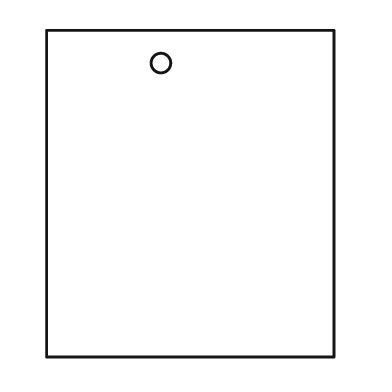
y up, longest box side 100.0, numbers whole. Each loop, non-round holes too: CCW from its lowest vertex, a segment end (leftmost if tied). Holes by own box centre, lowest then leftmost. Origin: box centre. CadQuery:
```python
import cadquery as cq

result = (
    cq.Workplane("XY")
    .moveTo(-44.0, -50.0)
    .lineTo(44.0, -50.0)
    .lineTo(44.0, 50.0)
    .lineTo(-44.0, 50.0)
    .close()
    .moveTo(-9.0, 40.0)
    .circle(3.0)
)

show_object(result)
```